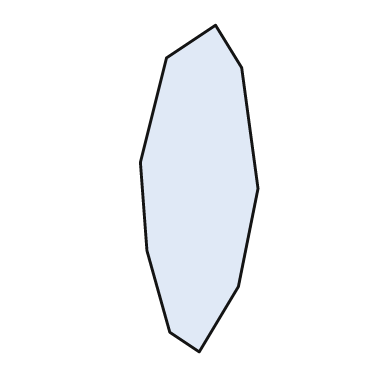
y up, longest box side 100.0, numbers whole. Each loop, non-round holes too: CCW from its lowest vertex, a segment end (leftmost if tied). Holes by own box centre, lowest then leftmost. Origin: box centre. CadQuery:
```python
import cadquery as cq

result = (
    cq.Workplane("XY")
    .moveTo(0.0, -50.0)
    .lineTo(12.0, -30.0)
    .lineTo(18.0, 0.0)
    .lineTo(13.0, 37.0)
    .lineTo(5.0, 50.0)
    .lineTo(-10.0, 40.0)
    .lineTo(-18.0, 8.0)
    .lineTo(-16.0, -19.0)
    .lineTo(-9.0, -44.0)
    .close()
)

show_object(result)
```